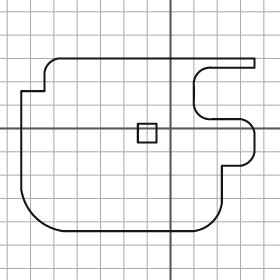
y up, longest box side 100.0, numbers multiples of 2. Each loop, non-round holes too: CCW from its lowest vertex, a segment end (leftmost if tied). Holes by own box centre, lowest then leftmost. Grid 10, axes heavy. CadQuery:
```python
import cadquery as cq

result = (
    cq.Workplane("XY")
    .moveTo(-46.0, -44.0)
    .lineTo(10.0, -44.0)
    .threePointArc((18.0, -40.0), (22.0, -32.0))
    .lineTo(22.0, -16.0)
    .lineTo(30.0, -16.0)
    .threePointArc((34.0, -14.0), (36.0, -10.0))
    .lineTo(36.0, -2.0)
    .threePointArc((34.0, 2.0), (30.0, 4.0))
    .lineTo(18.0, 4.0)
    .threePointArc((12.0, 6.0), (10.0, 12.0))
    .lineTo(10.0, 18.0)
    .threePointArc((12.0, 24.0), (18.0, 26.0))
    .lineTo(36.0, 26.0)
    .lineTo(36.0, 30.0)
    .lineTo(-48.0, 30.0)
    .threePointArc((-52.0, 28.0), (-54.0, 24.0))
    .lineTo(-54.0, 16.0)
    .lineTo(-64.0, 16.0)
    .lineTo(-64.0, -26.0)
    .threePointArc((-58.0, -38.0), (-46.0, -44.0))
    .close()
    .moveTo(-14.0, -6.0)
    .lineTo(-6.0, -6.0)
    .lineTo(-6.0, 2.0)
    .lineTo(-14.0, 2.0)
    .close()
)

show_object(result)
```